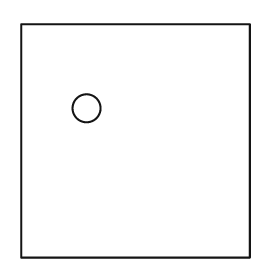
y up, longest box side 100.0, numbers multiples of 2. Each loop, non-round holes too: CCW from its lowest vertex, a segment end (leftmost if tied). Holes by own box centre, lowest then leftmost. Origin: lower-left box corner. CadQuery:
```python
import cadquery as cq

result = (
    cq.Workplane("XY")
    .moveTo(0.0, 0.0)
    .lineTo(98.0, 0.0)
    .lineTo(98.0, 100.0)
    .lineTo(0.0, 100.0)
    .close()
    .moveTo(28.0, 64.0)
    .circle(6.0)
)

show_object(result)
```